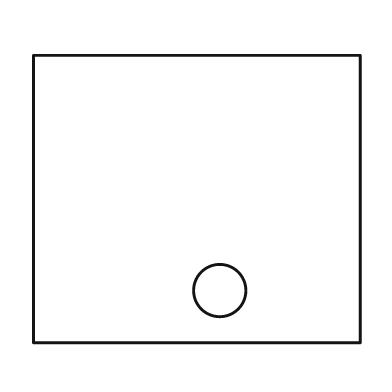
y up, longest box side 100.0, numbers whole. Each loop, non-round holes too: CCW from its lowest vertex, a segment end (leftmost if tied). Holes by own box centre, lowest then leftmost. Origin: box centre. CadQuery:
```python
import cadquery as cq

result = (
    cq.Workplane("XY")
    .moveTo(-50.0, -44.0)
    .lineTo(50.0, -44.0)
    .lineTo(50.0, 44.0)
    .lineTo(-50.0, 44.0)
    .close()
    .moveTo(7.0, -28.0)
    .circle(8.0)
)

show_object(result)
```